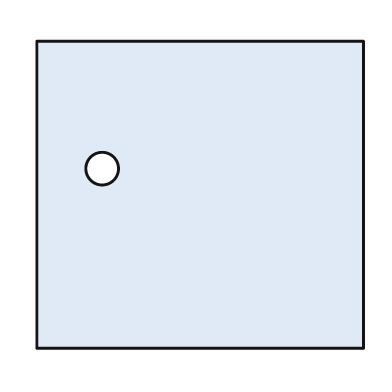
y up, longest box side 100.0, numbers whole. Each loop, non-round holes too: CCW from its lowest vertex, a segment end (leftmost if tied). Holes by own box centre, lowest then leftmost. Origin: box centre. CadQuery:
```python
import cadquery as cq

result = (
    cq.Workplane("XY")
    .moveTo(-50.0, -47.0)
    .lineTo(50.0, -47.0)
    .lineTo(50.0, 47.0)
    .lineTo(-50.0, 47.0)
    .close()
    .moveTo(-30.0, 8.0)
    .circle(5.0)
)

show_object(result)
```